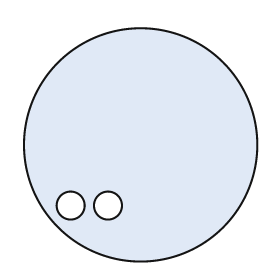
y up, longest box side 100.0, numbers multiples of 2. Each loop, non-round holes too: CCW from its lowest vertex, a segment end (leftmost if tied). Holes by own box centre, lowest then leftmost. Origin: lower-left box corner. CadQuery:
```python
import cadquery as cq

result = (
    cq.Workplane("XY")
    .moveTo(50.0, 50.0)
    .circle(50.0)
    .moveTo(20.0, 24.0)
    .circle(6.0)
    .moveTo(36.0, 24.0)
    .circle(6.0)
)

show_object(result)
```